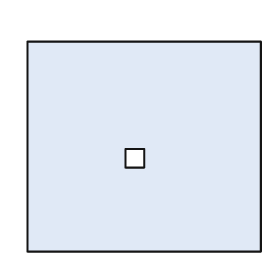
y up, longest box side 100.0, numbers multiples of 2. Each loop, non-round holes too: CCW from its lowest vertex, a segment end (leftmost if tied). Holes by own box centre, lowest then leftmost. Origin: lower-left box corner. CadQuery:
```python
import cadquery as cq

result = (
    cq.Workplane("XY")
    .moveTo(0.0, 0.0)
    .lineTo(100.0, 0.0)
    .lineTo(100.0, 90.0)
    .lineTo(0.0, 90.0)
    .close()
    .moveTo(42.0, 36.0)
    .lineTo(50.0, 36.0)
    .lineTo(50.0, 44.0)
    .lineTo(42.0, 44.0)
    .close()
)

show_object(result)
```